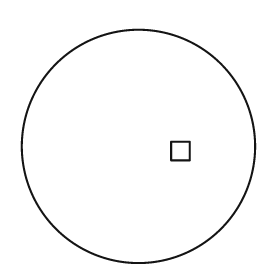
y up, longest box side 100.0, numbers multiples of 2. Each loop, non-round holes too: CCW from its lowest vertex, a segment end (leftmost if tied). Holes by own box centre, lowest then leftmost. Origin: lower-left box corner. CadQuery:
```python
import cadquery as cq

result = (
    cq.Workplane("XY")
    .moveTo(50.0, 50.0)
    .circle(50.0)
    .moveTo(64.0, 44.0)
    .lineTo(72.0, 44.0)
    .lineTo(72.0, 52.0)
    .lineTo(64.0, 52.0)
    .close()
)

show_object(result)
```